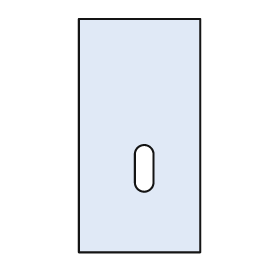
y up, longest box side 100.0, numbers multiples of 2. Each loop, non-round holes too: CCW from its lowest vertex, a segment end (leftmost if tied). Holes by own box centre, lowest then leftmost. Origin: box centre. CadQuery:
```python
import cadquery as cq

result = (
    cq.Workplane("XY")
    .moveTo(-26.0, -50.0)
    .lineTo(26.0, -50.0)
    .lineTo(26.0, 50.0)
    .lineTo(-26.0, 50.0)
    .close()
    .moveTo(-2.0, -20.0)
    .threePointArc((2.0, -24.0), (6.0, -20.0))
    .lineTo(6.0, -8.0)
    .threePointArc((2.0, -4.0), (-2.0, -8.0))
    .close()
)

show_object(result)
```